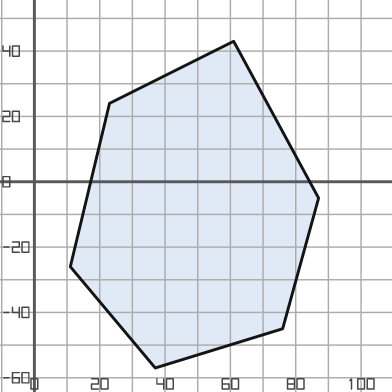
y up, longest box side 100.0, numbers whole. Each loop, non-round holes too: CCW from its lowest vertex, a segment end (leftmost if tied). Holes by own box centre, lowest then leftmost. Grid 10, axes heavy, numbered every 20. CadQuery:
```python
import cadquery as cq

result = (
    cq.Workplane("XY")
    .moveTo(37.0, -57.0)
    .lineTo(76.0, -45.0)
    .lineTo(87.0, -5.0)
    .lineTo(61.0, 43.0)
    .lineTo(23.0, 24.0)
    .lineTo(11.0, -26.0)
    .close()
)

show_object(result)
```